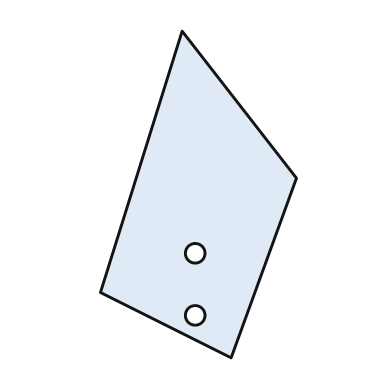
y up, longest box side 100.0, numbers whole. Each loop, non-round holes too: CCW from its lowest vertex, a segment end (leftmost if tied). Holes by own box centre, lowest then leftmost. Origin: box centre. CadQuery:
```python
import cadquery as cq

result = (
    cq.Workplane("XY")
    .moveTo(10.0, -50.0)
    .lineTo(30.0, 5.0)
    .lineTo(-5.0, 50.0)
    .lineTo(-30.0, -30.0)
    .close()
    .moveTo(-1.0, -37.0)
    .circle(3.0)
    .moveTo(-1.0, -18.0)
    .circle(3.0)
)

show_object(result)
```